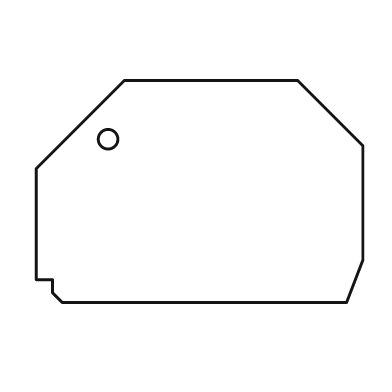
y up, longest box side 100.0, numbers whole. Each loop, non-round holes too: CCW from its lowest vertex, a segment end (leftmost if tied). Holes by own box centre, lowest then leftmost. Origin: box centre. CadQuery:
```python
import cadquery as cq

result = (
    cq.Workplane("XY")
    .moveTo(-42.0, -34.0)
    .lineTo(45.0, -34.0)
    .lineTo(50.0, -21.0)
    .lineTo(50.0, 14.0)
    .lineTo(30.0, 34.0)
    .lineTo(-23.0, 34.0)
    .lineTo(-50.0, 7.0)
    .lineTo(-50.0, -27.0)
    .lineTo(-45.0, -27.0)
    .lineTo(-45.0, -31.0)
    .close()
    .moveTo(-28.0, 16.0)
    .circle(3.0)
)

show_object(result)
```